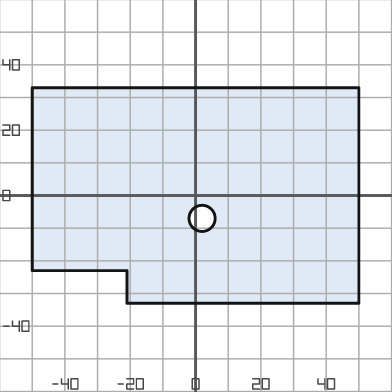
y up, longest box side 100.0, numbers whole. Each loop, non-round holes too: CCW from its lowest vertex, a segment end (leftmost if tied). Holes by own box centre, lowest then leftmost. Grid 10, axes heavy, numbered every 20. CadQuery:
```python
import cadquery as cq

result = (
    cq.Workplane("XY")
    .moveTo(-21.0, -33.0)
    .lineTo(50.0, -33.0)
    .lineTo(50.0, 33.0)
    .lineTo(-50.0, 33.0)
    .lineTo(-50.0, -23.0)
    .lineTo(-21.0, -23.0)
    .close()
    .moveTo(2.0, -7.0)
    .circle(4.0)
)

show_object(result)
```